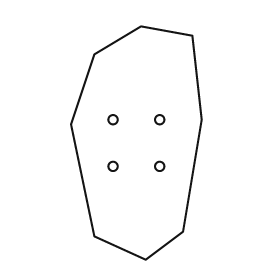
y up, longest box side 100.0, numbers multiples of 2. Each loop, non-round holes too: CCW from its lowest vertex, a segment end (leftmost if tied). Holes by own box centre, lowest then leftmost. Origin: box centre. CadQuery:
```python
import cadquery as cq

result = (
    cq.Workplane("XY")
    .moveTo(4.0, -50.0)
    .lineTo(20.0, -38.0)
    .lineTo(28.0, 10.0)
    .lineTo(24.0, 46.0)
    .lineTo(2.0, 50.0)
    .lineTo(-18.0, 38.0)
    .lineTo(-28.0, 8.0)
    .lineTo(-18.0, -40.0)
    .close()
    .moveTo(-10.0, -10.0)
    .circle(2.0)
    .moveTo(10.0, -10.0)
    .circle(2.0)
    .moveTo(-10.0, 10.0)
    .circle(2.0)
    .moveTo(10.0, 10.0)
    .circle(2.0)
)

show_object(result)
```